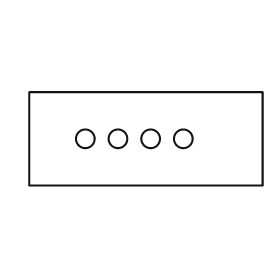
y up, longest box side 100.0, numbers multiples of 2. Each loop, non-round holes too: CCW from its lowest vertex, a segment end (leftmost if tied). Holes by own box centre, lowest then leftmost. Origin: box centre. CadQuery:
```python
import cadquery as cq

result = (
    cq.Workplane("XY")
    .moveTo(-50.0, -20.0)
    .lineTo(50.0, -20.0)
    .lineTo(50.0, 20.0)
    .lineTo(-50.0, 20.0)
    .close()
    .moveTo(-26.0, 0.0)
    .circle(4.0)
    .moveTo(-12.0, 0.0)
    .circle(4.0)
    .moveTo(2.0, 0.0)
    .circle(4.0)
    .moveTo(16.0, 0.0)
    .circle(4.0)
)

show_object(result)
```